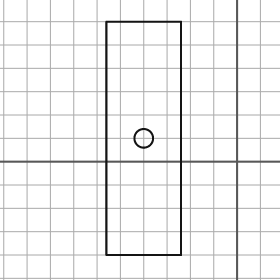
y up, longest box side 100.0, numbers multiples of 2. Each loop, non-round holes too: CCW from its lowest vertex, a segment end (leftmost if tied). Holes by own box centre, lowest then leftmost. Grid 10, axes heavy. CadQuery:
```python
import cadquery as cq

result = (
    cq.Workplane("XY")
    .moveTo(-56.0, -40.0)
    .lineTo(-24.0, -40.0)
    .lineTo(-24.0, 60.0)
    .lineTo(-56.0, 60.0)
    .close()
    .moveTo(-40.0, 10.0)
    .circle(4.0)
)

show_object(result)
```